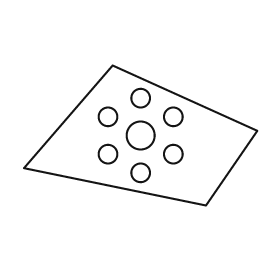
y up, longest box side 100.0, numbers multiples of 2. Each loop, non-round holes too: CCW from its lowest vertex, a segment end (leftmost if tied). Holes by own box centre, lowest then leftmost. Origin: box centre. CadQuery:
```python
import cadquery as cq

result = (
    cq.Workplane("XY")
    .moveTo(28.0, -30.0)
    .lineTo(50.0, 2.0)
    .lineTo(-12.0, 30.0)
    .lineTo(-50.0, -14.0)
    .close()
    .moveTo(0.0, -16.0)
    .circle(4.0)
    .moveTo(-14.0, -8.0)
    .circle(4.0)
    .moveTo(14.0, -8.0)
    .circle(4.0)
    .moveTo(0.0, 0.0)
    .circle(6.0)
    .moveTo(-14.0, 8.0)
    .circle(4.0)
    .moveTo(14.0, 8.0)
    .circle(4.0)
    .moveTo(0.0, 16.0)
    .circle(4.0)
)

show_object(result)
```